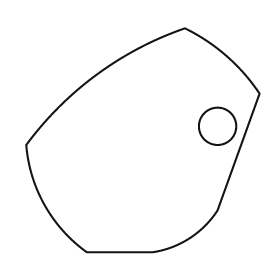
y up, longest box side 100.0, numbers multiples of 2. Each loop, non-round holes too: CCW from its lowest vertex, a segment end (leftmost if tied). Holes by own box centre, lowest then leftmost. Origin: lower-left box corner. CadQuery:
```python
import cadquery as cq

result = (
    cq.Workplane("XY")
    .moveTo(26.0, 0.0)
    .lineTo(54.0, 0.0)
    .threePointArc((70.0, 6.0), (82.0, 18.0))
    .lineTo(100.0, 68.0)
    .threePointArc((86.0, 84.0), (68.0, 96.0))
    .threePointArc((30.0, 76.0), (0.0, 46.0))
    .threePointArc((8.0, 20.0), (26.0, 0.0))
    .close()
    .moveTo(82.0, 54.0)
    .circle(8.0)
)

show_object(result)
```